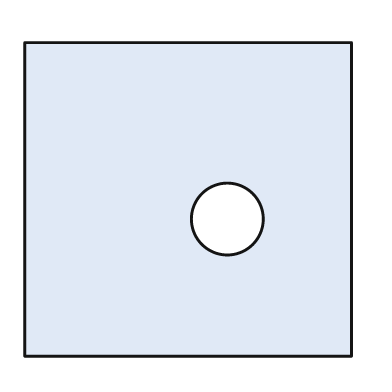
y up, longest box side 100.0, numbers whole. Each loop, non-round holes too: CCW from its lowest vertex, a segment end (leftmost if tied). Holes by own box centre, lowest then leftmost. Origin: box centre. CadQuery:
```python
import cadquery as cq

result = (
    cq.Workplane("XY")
    .moveTo(-50.0, -48.0)
    .lineTo(50.0, -48.0)
    .lineTo(50.0, 48.0)
    .lineTo(-50.0, 48.0)
    .close()
    .moveTo(12.0, -6.0)
    .circle(11.0)
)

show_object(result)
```